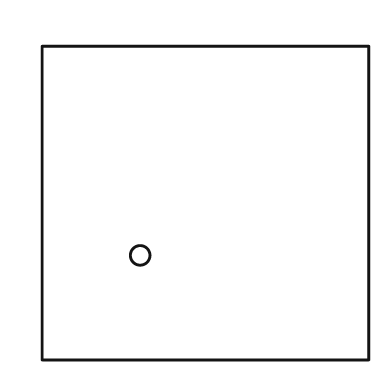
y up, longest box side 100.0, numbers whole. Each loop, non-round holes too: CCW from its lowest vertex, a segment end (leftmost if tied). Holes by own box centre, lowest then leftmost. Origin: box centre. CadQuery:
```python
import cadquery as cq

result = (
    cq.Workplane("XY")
    .moveTo(-50.0, -48.0)
    .lineTo(50.0, -48.0)
    .lineTo(50.0, 48.0)
    .lineTo(-50.0, 48.0)
    .close()
    .moveTo(-20.0, -16.0)
    .circle(3.0)
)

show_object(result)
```